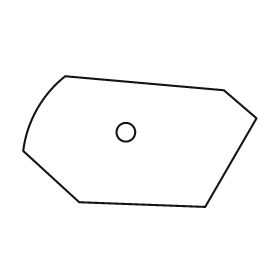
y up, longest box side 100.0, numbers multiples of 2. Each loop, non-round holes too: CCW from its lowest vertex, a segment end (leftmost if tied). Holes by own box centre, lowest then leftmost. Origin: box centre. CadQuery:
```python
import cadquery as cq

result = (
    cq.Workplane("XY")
    .moveTo(28.0, -28.0)
    .lineTo(50.0, 10.0)
    .lineTo(36.0, 22.0)
    .lineTo(-32.0, 28.0)
    .threePointArc((-44.0, 14.0), (-50.0, -4.0))
    .lineTo(-26.0, -26.0)
    .close()
    .moveTo(-6.0, 4.0)
    .circle(4.0)
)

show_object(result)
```